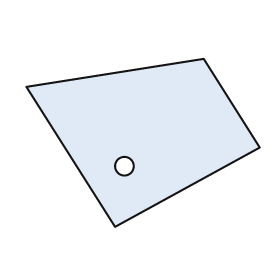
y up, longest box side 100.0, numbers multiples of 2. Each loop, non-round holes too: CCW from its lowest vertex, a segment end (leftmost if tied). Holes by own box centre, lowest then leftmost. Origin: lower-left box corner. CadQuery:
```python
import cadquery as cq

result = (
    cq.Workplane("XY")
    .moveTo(38.0, 0.0)
    .lineTo(100.0, 34.0)
    .lineTo(76.0, 72.0)
    .lineTo(0.0, 60.0)
    .close()
    .moveTo(42.0, 26.0)
    .circle(4.0)
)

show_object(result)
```